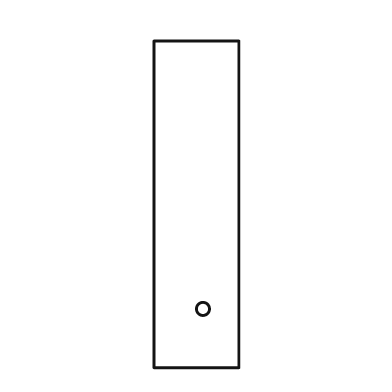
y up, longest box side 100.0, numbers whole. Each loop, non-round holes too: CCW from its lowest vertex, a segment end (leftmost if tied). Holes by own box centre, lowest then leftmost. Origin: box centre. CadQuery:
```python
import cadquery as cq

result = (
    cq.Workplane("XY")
    .moveTo(-13.0, -50.0)
    .lineTo(13.0, -50.0)
    .lineTo(13.0, 50.0)
    .lineTo(-13.0, 50.0)
    .close()
    .moveTo(2.0, -32.0)
    .circle(2.0)
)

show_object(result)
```